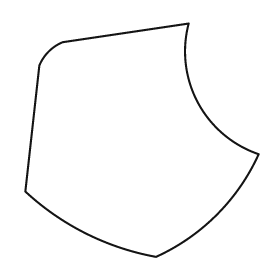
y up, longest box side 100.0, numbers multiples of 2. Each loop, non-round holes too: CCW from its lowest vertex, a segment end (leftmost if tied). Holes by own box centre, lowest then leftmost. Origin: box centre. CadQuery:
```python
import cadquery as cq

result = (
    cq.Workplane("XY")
    .moveTo(6.0, -50.0)
    .threePointArc((32.0, -32.0), (50.0, -6.0))
    .threePointArc((24.0, 16.0), (20.0, 50.0))
    .lineTo(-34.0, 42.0)
    .threePointArc((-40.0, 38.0), (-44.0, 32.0))
    .lineTo(-50.0, -22.0)
    .threePointArc((-24.0, -40.0), (6.0, -50.0))
    .close()
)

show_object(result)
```